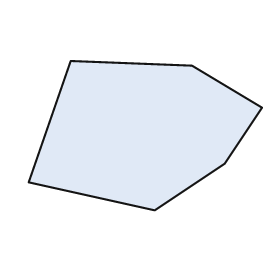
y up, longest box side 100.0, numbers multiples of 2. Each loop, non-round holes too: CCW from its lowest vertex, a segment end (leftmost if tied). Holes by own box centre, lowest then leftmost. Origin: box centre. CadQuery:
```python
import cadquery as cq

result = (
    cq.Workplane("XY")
    .moveTo(4.0, -32.0)
    .lineTo(34.0, -12.0)
    .lineTo(50.0, 12.0)
    .lineTo(20.0, 30.0)
    .lineTo(-32.0, 32.0)
    .lineTo(-50.0, -20.0)
    .close()
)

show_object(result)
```